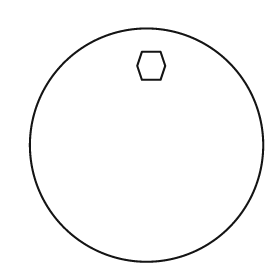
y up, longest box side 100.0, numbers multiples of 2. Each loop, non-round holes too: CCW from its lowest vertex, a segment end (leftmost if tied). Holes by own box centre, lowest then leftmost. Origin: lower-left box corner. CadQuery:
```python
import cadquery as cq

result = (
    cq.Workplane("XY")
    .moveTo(50.0, 50.0)
    .circle(50.0)
    .moveTo(48.0, 78.0)
    .lineTo(56.0, 78.0)
    .lineTo(58.0, 84.0)
    .lineTo(56.0, 90.0)
    .lineTo(48.0, 90.0)
    .lineTo(46.0, 84.0)
    .close()
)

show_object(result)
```